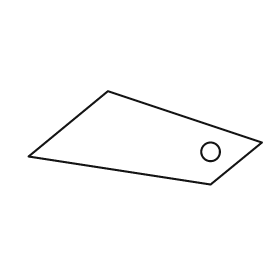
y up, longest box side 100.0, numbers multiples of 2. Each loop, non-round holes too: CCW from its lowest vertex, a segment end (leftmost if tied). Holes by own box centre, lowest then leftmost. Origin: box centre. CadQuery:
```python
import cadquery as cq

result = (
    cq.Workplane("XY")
    .moveTo(28.0, -20.0)
    .lineTo(50.0, -2.0)
    .lineTo(-16.0, 20.0)
    .lineTo(-50.0, -8.0)
    .close()
    .moveTo(28.0, -6.0)
    .circle(4.0)
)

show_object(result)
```